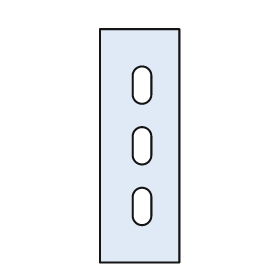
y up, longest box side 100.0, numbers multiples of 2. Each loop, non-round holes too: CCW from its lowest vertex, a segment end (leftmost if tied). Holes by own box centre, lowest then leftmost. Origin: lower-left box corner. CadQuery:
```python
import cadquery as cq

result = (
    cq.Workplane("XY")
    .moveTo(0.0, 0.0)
    .lineTo(34.0, 0.0)
    .lineTo(34.0, 100.0)
    .lineTo(0.0, 100.0)
    .close()
    .moveTo(14.0, 20.0)
    .threePointArc((18.0, 16.0), (22.0, 20.0))
    .lineTo(22.0, 28.0)
    .threePointArc((18.0, 32.0), (14.0, 28.0))
    .close()
    .moveTo(14.0, 46.0)
    .threePointArc((18.0, 42.0), (22.0, 46.0))
    .lineTo(22.0, 54.0)
    .threePointArc((18.0, 58.0), (14.0, 54.0))
    .close()
    .moveTo(14.0, 72.0)
    .threePointArc((18.0, 68.0), (22.0, 72.0))
    .lineTo(22.0, 80.0)
    .threePointArc((18.0, 84.0), (14.0, 80.0))
    .close()
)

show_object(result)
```